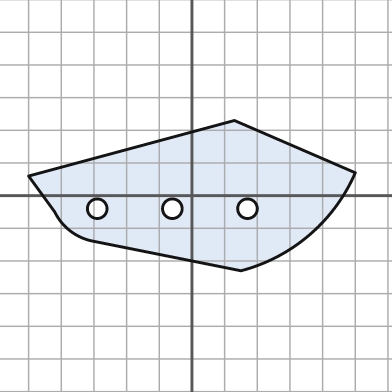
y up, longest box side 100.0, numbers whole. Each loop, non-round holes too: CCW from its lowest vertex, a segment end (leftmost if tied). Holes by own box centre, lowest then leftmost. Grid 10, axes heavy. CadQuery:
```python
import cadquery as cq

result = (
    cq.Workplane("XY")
    .moveTo(15.0, -23.0)
    .threePointArc((36.0, -12.0), (50.0, 7.0))
    .lineTo(13.0, 23.0)
    .lineTo(-50.0, 6.0)
    .lineTo(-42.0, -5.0)
    .threePointArc((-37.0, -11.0), (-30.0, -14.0))
    .close()
    .moveTo(-29.0, -4.0)
    .circle(3.0)
    .moveTo(-6.0, -4.0)
    .circle(3.0)
    .moveTo(17.0, -4.0)
    .circle(3.0)
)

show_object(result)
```